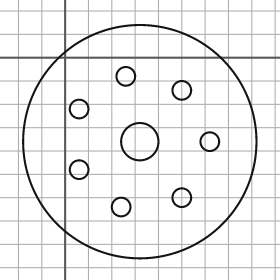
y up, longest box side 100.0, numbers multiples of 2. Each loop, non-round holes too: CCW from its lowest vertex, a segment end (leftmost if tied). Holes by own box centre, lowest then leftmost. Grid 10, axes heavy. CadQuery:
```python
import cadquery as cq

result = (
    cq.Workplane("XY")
    .moveTo(32.0, -36.0)
    .circle(50.0)
    .moveTo(24.0, -64.0)
    .circle(4.0)
    .moveTo(50.0, -60.0)
    .circle(4.0)
    .moveTo(6.0, -48.0)
    .circle(4.0)
    .moveTo(32.0, -36.0)
    .circle(8.0)
    .moveTo(62.0, -36.0)
    .circle(4.0)
    .moveTo(6.0, -22.0)
    .circle(4.0)
    .moveTo(50.0, -14.0)
    .circle(4.0)
    .moveTo(26.0, -8.0)
    .circle(4.0)
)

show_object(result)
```